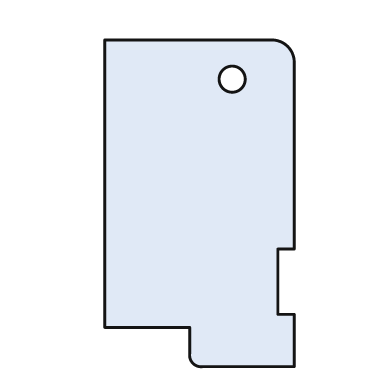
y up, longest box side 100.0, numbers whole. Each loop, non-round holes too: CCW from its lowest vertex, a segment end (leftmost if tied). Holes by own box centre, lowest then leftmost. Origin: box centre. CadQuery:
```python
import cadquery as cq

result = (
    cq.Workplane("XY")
    .moveTo(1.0, -50.0)
    .lineTo(29.0, -50.0)
    .lineTo(29.0, -34.0)
    .lineTo(24.0, -34.0)
    .lineTo(24.0, -14.0)
    .lineTo(29.0, -14.0)
    .lineTo(29.0, 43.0)
    .threePointArc((27.0, 48.0), (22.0, 50.0))
    .lineTo(-29.0, 50.0)
    .lineTo(-29.0, -38.0)
    .lineTo(-3.0, -38.0)
    .lineTo(-3.0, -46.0)
    .threePointArc((-2.0, -49.0), (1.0, -50.0))
    .close()
    .moveTo(10.0, 38.0)
    .circle(4.0)
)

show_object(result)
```